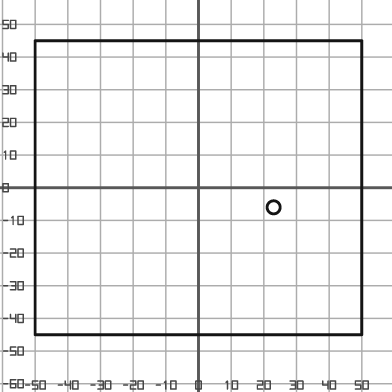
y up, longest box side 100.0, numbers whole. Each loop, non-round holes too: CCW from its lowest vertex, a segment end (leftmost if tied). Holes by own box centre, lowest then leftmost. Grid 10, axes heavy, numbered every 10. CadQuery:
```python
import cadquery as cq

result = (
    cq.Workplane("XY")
    .moveTo(-50.0, -45.0)
    .lineTo(50.0, -45.0)
    .lineTo(50.0, 45.0)
    .lineTo(-50.0, 45.0)
    .close()
    .moveTo(23.0, -6.0)
    .circle(2.0)
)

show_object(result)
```